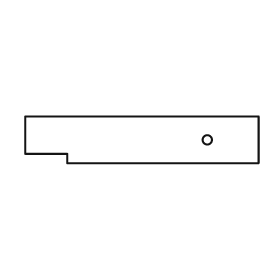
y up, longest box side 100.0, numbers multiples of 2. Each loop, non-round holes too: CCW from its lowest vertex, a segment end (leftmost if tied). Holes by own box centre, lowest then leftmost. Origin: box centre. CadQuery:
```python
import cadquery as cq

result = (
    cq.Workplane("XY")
    .moveTo(-32.0, -10.0)
    .lineTo(50.0, -10.0)
    .lineTo(50.0, 10.0)
    .lineTo(-50.0, 10.0)
    .lineTo(-50.0, -6.0)
    .lineTo(-32.0, -6.0)
    .close()
    .moveTo(28.0, 0.0)
    .circle(2.0)
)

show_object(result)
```